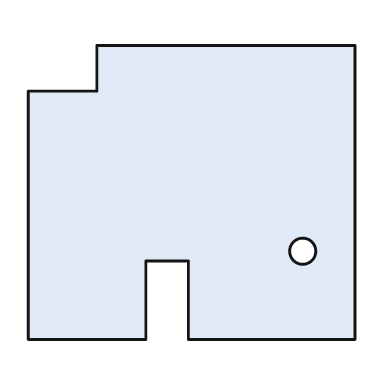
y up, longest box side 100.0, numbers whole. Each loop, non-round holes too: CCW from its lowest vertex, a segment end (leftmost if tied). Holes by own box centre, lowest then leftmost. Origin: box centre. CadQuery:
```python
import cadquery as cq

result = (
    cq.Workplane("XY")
    .moveTo(-50.0, -45.0)
    .lineTo(-14.0, -45.0)
    .lineTo(-14.0, -21.0)
    .lineTo(-1.0, -21.0)
    .lineTo(-1.0, -45.0)
    .lineTo(50.0, -45.0)
    .lineTo(50.0, 45.0)
    .lineTo(-29.0, 45.0)
    .lineTo(-29.0, 31.0)
    .lineTo(-50.0, 31.0)
    .close()
    .moveTo(34.0, -18.0)
    .circle(4.0)
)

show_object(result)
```